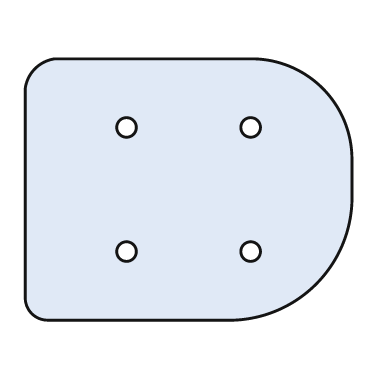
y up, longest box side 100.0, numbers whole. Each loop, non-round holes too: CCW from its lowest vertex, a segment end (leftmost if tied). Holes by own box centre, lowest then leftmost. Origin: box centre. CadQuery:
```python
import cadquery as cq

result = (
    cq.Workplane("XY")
    .moveTo(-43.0, -40.0)
    .lineTo(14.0, -40.0)
    .threePointArc((39.0, -29.0), (50.0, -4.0))
    .lineTo(50.0, 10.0)
    .threePointArc((41.0, 31.0), (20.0, 40.0))
    .lineTo(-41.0, 40.0)
    .threePointArc((-47.0, 37.0), (-50.0, 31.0))
    .lineTo(-50.0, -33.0)
    .threePointArc((-48.0, -38.0), (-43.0, -40.0))
    .close()
    .moveTo(-19.0, -19.0)
    .circle(3.0)
    .moveTo(19.0, -19.0)
    .circle(3.0)
    .moveTo(-19.0, 19.0)
    .circle(3.0)
    .moveTo(19.0, 19.0)
    .circle(3.0)
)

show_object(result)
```